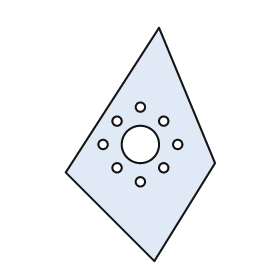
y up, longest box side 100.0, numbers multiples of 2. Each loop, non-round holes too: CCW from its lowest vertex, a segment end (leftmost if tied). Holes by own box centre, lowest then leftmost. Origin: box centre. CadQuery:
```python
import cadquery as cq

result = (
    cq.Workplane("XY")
    .moveTo(6.0, -50.0)
    .lineTo(32.0, -8.0)
    .lineTo(8.0, 50.0)
    .lineTo(-32.0, -12.0)
    .close()
    .moveTo(0.0, -16.0)
    .circle(2.0)
    .moveTo(-10.0, -10.0)
    .circle(2.0)
    .moveTo(10.0, -10.0)
    .circle(2.0)
    .moveTo(-16.0, 0.0)
    .circle(2.0)
    .moveTo(0.0, 0.0)
    .circle(8.0)
    .moveTo(16.0, 0.0)
    .circle(2.0)
    .moveTo(-10.0, 10.0)
    .circle(2.0)
    .moveTo(10.0, 10.0)
    .circle(2.0)
    .moveTo(0.0, 16.0)
    .circle(2.0)
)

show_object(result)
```